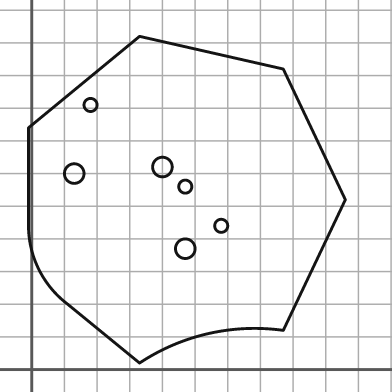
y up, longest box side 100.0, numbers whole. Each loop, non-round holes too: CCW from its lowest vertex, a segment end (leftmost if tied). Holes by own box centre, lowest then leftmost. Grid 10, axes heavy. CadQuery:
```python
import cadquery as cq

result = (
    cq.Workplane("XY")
    .moveTo(33.0, 2.0)
    .threePointArc((54.0, 11.0), (77.0, 12.0))
    .lineTo(96.0, 52.0)
    .lineTo(77.0, 92.0)
    .lineTo(33.0, 102.0)
    .lineTo(-1.0, 74.0)
    .lineTo(-1.0, 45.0)
    .threePointArc((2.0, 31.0), (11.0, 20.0))
    .close()
    .moveTo(47.0, 37.0)
    .circle(3.0)
    .moveTo(58.0, 44.0)
    .circle(2.0)
    .moveTo(47.0, 56.0)
    .circle(2.0)
    .moveTo(13.0, 60.0)
    .circle(3.0)
    .moveTo(40.0, 62.0)
    .circle(3.0)
    .moveTo(18.0, 81.0)
    .circle(2.0)
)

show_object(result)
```